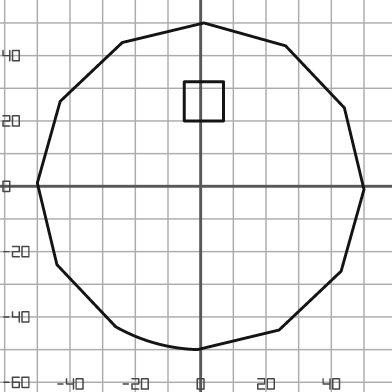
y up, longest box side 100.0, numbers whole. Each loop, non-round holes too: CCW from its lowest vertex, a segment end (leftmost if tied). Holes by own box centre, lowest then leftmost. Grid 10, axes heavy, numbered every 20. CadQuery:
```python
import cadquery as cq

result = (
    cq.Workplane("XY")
    .moveTo(-1.0, -50.0)
    .lineTo(24.0, -44.0)
    .lineTo(43.0, -26.0)
    .lineTo(50.0, -1.0)
    .lineTo(44.0, 24.0)
    .lineTo(26.0, 43.0)
    .lineTo(1.0, 50.0)
    .lineTo(-24.0, 44.0)
    .lineTo(-43.0, 26.0)
    .lineTo(-50.0, 1.0)
    .lineTo(-44.0, -24.0)
    .lineTo(-26.0, -43.0)
    .threePointArc((-14.0, -48.0), (-1.0, -50.0))
    .close()
    .moveTo(-5.0, 20.0)
    .lineTo(7.0, 20.0)
    .lineTo(7.0, 32.0)
    .lineTo(-5.0, 32.0)
    .close()
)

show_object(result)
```